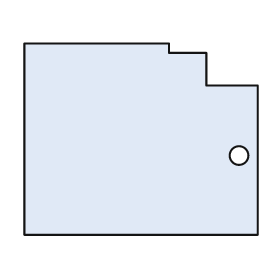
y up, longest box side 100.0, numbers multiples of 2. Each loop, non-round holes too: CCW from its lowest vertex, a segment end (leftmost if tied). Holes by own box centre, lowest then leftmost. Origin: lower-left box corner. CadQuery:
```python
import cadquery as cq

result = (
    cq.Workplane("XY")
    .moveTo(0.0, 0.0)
    .lineTo(100.0, 0.0)
    .lineTo(100.0, 64.0)
    .lineTo(78.0, 64.0)
    .lineTo(78.0, 78.0)
    .lineTo(62.0, 78.0)
    .lineTo(62.0, 82.0)
    .lineTo(0.0, 82.0)
    .close()
    .moveTo(92.0, 34.0)
    .circle(4.0)
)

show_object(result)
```